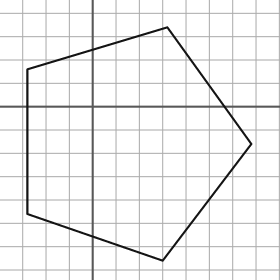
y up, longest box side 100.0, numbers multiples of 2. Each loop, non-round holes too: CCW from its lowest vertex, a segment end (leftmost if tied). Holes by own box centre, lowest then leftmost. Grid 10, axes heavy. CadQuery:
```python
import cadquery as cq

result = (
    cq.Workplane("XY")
    .moveTo(30.0, -66.0)
    .lineTo(68.0, -16.0)
    .lineTo(32.0, 34.0)
    .lineTo(-28.0, 16.0)
    .lineTo(-28.0, -46.0)
    .close()
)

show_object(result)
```